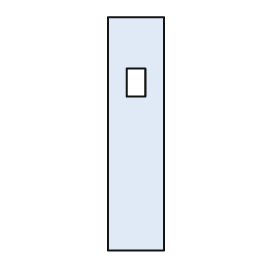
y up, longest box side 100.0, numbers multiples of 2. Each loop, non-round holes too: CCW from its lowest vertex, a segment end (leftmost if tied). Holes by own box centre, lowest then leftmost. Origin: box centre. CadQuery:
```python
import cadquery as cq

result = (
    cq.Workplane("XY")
    .moveTo(-12.0, -50.0)
    .lineTo(12.0, -50.0)
    .lineTo(12.0, 50.0)
    .lineTo(-12.0, 50.0)
    .close()
    .moveTo(-4.0, 16.0)
    .lineTo(4.0, 16.0)
    .lineTo(4.0, 28.0)
    .lineTo(-4.0, 28.0)
    .close()
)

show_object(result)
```